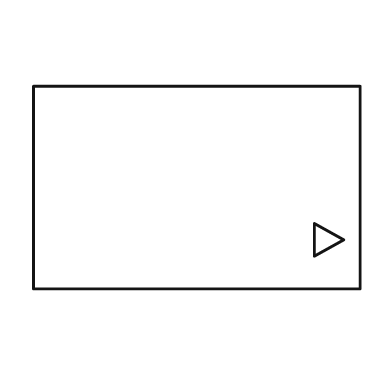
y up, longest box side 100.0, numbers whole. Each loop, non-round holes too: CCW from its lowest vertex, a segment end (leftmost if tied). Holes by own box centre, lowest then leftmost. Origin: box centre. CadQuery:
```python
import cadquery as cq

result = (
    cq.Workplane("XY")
    .moveTo(-50.0, -31.0)
    .lineTo(50.0, -31.0)
    .lineTo(50.0, 31.0)
    .lineTo(-50.0, 31.0)
    .close()
    .moveTo(36.0, -21.0)
    .lineTo(45.0, -16.0)
    .lineTo(36.0, -11.0)
    .close()
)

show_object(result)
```